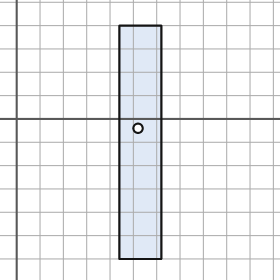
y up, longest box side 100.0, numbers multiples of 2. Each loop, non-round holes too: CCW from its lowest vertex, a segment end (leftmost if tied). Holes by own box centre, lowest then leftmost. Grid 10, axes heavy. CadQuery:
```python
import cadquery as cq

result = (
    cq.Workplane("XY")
    .moveTo(44.0, -60.0)
    .lineTo(62.0, -60.0)
    .lineTo(62.0, 40.0)
    .lineTo(44.0, 40.0)
    .close()
    .moveTo(52.0, -4.0)
    .circle(2.0)
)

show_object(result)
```